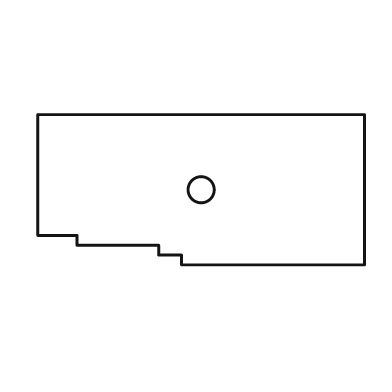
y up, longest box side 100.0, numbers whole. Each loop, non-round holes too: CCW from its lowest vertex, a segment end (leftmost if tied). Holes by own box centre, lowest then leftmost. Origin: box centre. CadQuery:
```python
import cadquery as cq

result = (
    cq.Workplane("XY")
    .moveTo(-6.0, -23.0)
    .lineTo(50.0, -23.0)
    .lineTo(50.0, 23.0)
    .lineTo(-50.0, 23.0)
    .lineTo(-50.0, -14.0)
    .lineTo(-38.0, -14.0)
    .lineTo(-38.0, -17.0)
    .lineTo(-13.0, -17.0)
    .lineTo(-13.0, -20.0)
    .lineTo(-6.0, -20.0)
    .close()
    .moveTo(0.0, 0.0)
    .circle(4.0)
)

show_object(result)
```